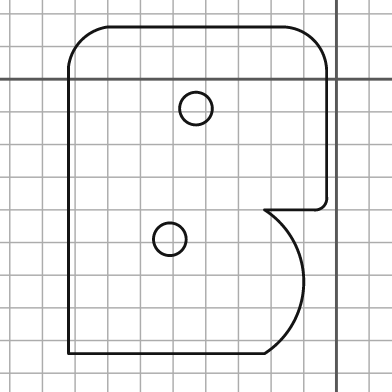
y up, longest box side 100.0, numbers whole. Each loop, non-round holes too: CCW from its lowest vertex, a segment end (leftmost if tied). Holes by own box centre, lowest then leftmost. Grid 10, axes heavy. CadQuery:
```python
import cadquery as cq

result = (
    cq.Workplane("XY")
    .moveTo(-82.0, -84.0)
    .lineTo(-22.0, -84.0)
    .threePointArc((-10.0, -62.0), (-22.0, -40.0))
    .lineTo(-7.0, -40.0)
    .threePointArc((-4.0, -39.0), (-3.0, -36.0))
    .lineTo(-3.0, 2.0)
    .threePointArc((-7.0, 12.0), (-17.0, 16.0))
    .lineTo(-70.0, 16.0)
    .threePointArc((-78.0, 12.0), (-82.0, 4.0))
    .close()
    .moveTo(-51.0, -49.0)
    .circle(5.0)
    .moveTo(-43.0, -9.0)
    .circle(5.0)
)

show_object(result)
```